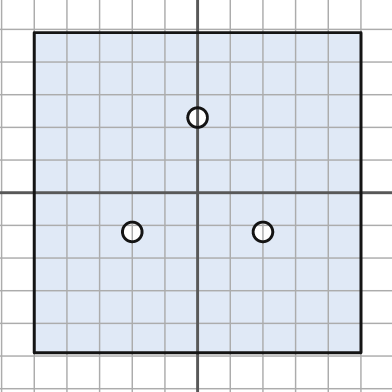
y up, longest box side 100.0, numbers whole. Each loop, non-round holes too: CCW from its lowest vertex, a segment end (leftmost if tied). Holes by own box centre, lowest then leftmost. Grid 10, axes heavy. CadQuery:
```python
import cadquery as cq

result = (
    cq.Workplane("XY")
    .moveTo(-50.0, -49.0)
    .lineTo(50.0, -49.0)
    .lineTo(50.0, 49.0)
    .lineTo(-50.0, 49.0)
    .close()
    .moveTo(-20.0, -12.0)
    .circle(3.0)
    .moveTo(20.0, -12.0)
    .circle(3.0)
    .moveTo(0.0, 23.0)
    .circle(3.0)
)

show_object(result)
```